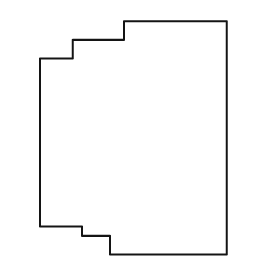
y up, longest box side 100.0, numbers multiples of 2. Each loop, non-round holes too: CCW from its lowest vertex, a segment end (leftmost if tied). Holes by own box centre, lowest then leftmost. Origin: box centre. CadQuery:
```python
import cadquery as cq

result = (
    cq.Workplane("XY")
    .moveTo(-10.0, -50.0)
    .lineTo(40.0, -50.0)
    .lineTo(40.0, 50.0)
    .lineTo(-4.0, 50.0)
    .lineTo(-4.0, 42.0)
    .lineTo(-26.0, 42.0)
    .lineTo(-26.0, 34.0)
    .lineTo(-40.0, 34.0)
    .lineTo(-40.0, -38.0)
    .lineTo(-22.0, -38.0)
    .lineTo(-22.0, -42.0)
    .lineTo(-10.0, -42.0)
    .close()
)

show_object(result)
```